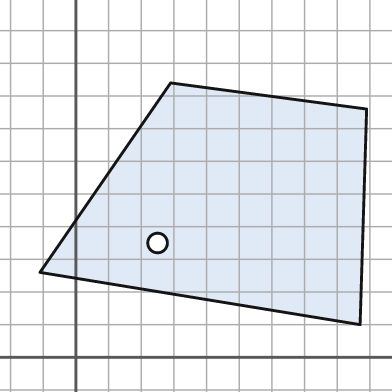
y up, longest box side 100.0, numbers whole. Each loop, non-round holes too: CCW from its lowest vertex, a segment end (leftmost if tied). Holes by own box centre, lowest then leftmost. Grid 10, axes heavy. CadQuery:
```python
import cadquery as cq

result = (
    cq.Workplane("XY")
    .moveTo(87.0, 10.0)
    .lineTo(89.0, 76.0)
    .lineTo(29.0, 84.0)
    .lineTo(-11.0, 26.0)
    .close()
    .moveTo(25.0, 35.0)
    .circle(3.0)
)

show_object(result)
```